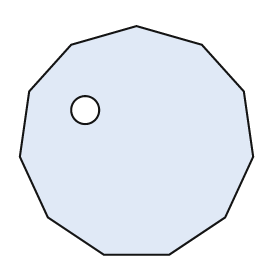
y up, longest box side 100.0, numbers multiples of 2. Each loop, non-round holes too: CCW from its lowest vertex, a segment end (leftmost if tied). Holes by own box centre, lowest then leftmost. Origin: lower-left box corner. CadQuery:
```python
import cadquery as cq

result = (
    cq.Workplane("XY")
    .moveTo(36.0, 0.0)
    .lineTo(64.0, 0.0)
    .lineTo(88.0, 16.0)
    .lineTo(100.0, 42.0)
    .lineTo(96.0, 70.0)
    .lineTo(78.0, 90.0)
    .lineTo(50.0, 98.0)
    .lineTo(22.0, 90.0)
    .lineTo(4.0, 70.0)
    .lineTo(0.0, 42.0)
    .lineTo(12.0, 16.0)
    .close()
    .moveTo(28.0, 62.0)
    .circle(6.0)
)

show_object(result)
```